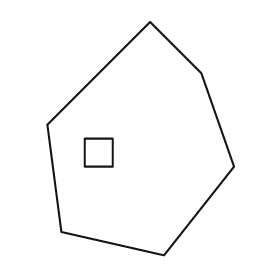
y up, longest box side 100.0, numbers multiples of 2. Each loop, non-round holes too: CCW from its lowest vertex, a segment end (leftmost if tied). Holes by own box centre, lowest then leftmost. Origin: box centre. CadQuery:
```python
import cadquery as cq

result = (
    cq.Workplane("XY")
    .moveTo(10.0, -50.0)
    .lineTo(40.0, -12.0)
    .lineTo(26.0, 28.0)
    .lineTo(4.0, 50.0)
    .lineTo(-40.0, 6.0)
    .lineTo(-34.0, -40.0)
    .close()
    .moveTo(-24.0, -12.0)
    .lineTo(-12.0, -12.0)
    .lineTo(-12.0, 0.0)
    .lineTo(-24.0, 0.0)
    .close()
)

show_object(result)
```